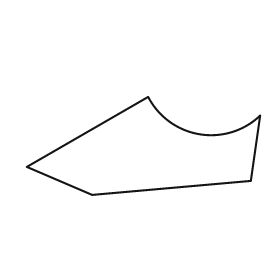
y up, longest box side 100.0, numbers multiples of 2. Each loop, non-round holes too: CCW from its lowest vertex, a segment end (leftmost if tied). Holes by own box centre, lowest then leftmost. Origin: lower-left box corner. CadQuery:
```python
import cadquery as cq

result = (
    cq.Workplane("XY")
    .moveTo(28.0, 0.0)
    .lineTo(96.0, 6.0)
    .lineTo(100.0, 34.0)
    .threePointArc((74.0, 26.0), (52.0, 42.0))
    .lineTo(0.0, 12.0)
    .close()
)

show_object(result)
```